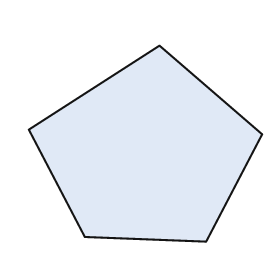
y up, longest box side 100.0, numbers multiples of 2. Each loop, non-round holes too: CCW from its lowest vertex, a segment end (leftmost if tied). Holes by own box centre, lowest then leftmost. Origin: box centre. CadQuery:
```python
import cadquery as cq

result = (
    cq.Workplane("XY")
    .moveTo(26.0, -42.0)
    .lineTo(50.0, 4.0)
    .lineTo(6.0, 42.0)
    .lineTo(-50.0, 6.0)
    .lineTo(-26.0, -40.0)
    .close()
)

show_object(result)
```